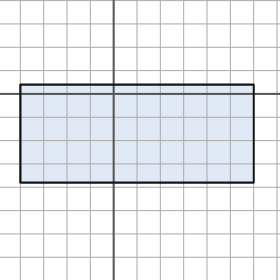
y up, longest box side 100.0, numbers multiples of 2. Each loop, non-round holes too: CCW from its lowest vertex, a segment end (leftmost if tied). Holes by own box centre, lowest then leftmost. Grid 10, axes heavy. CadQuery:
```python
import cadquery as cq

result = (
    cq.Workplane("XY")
    .moveTo(-40.0, -38.0)
    .lineTo(60.0, -38.0)
    .lineTo(60.0, 4.0)
    .lineTo(-40.0, 4.0)
    .close()
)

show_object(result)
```